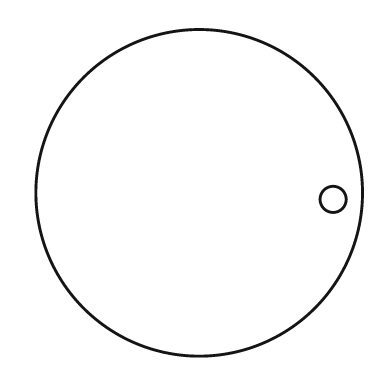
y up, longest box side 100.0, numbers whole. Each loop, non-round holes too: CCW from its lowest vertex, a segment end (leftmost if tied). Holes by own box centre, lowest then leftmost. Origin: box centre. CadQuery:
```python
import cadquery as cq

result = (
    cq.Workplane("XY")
    .moveTo(0.0, 0.0)
    .circle(50.0)
    .moveTo(41.0, -2.0)
    .circle(4.0)
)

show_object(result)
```